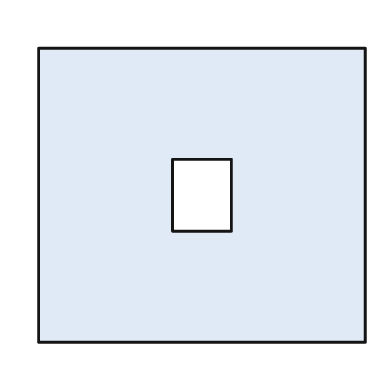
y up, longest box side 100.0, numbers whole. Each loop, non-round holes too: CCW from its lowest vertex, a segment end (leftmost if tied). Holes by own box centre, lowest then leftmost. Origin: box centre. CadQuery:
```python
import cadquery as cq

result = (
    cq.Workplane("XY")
    .moveTo(-50.0, -45.0)
    .lineTo(50.0, -45.0)
    .lineTo(50.0, 45.0)
    .lineTo(-50.0, 45.0)
    .close()
    .moveTo(-9.0, -11.0)
    .lineTo(9.0, -11.0)
    .lineTo(9.0, 11.0)
    .lineTo(-9.0, 11.0)
    .close()
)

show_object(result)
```